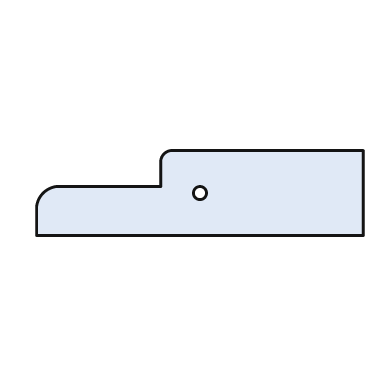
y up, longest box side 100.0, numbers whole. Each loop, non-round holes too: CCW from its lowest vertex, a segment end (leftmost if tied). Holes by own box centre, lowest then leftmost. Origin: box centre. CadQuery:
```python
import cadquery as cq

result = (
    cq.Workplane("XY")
    .moveTo(-50.0, -13.0)
    .lineTo(50.0, -13.0)
    .lineTo(50.0, 13.0)
    .lineTo(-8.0, 13.0)
    .threePointArc((-11.0, 12.0), (-12.0, 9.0))
    .lineTo(-12.0, 2.0)
    .lineTo(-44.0, 2.0)
    .threePointArc((-48.0, 0.0), (-50.0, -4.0))
    .close()
    .moveTo(0.0, 0.0)
    .circle(2.0)
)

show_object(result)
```